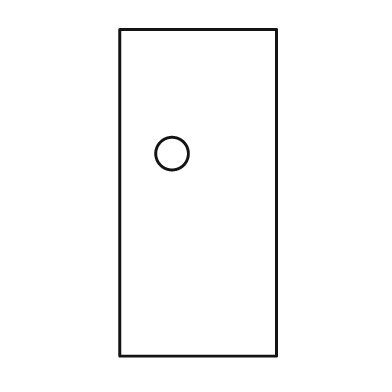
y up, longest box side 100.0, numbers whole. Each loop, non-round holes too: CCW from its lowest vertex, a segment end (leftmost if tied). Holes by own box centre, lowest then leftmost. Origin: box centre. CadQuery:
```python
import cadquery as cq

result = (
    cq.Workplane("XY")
    .moveTo(-24.0, -50.0)
    .lineTo(24.0, -50.0)
    .lineTo(24.0, 50.0)
    .lineTo(-24.0, 50.0)
    .close()
    .moveTo(-8.0, 12.0)
    .circle(5.0)
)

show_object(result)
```